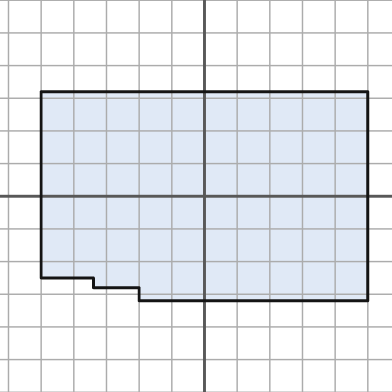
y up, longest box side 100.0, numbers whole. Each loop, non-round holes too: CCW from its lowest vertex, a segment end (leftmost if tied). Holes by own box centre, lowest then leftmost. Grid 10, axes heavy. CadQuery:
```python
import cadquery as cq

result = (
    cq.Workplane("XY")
    .moveTo(-20.0, -32.0)
    .lineTo(50.0, -32.0)
    .lineTo(50.0, 32.0)
    .lineTo(-50.0, 32.0)
    .lineTo(-50.0, -25.0)
    .lineTo(-34.0, -25.0)
    .lineTo(-34.0, -28.0)
    .lineTo(-20.0, -28.0)
    .close()
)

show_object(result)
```